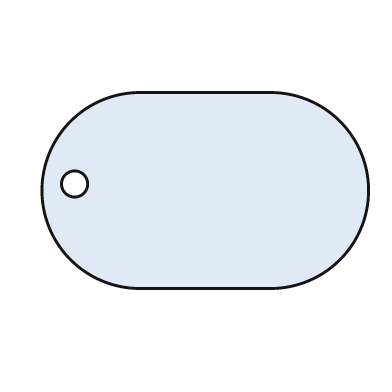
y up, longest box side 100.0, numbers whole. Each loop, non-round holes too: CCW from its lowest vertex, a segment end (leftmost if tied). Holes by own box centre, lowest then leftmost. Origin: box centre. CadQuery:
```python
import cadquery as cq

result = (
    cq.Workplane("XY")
    .moveTo(-20.0, -30.0)
    .lineTo(20.0, -30.0)
    .threePointArc((50.0, 0.0), (20.0, 30.0))
    .lineTo(-20.0, 30.0)
    .threePointArc((-50.0, 0.0), (-20.0, -30.0))
    .close()
    .moveTo(-40.0, 2.0)
    .circle(4.0)
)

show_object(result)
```